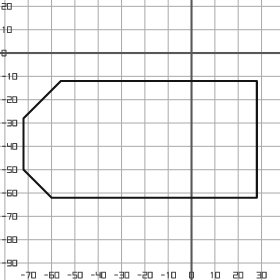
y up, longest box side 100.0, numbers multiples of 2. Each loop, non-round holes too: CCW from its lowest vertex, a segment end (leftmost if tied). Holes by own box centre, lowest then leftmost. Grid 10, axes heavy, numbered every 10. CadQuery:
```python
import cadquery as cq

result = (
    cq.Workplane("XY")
    .moveTo(-60.0, -62.0)
    .lineTo(28.0, -62.0)
    .lineTo(28.0, -12.0)
    .lineTo(-56.0, -12.0)
    .lineTo(-72.0, -28.0)
    .lineTo(-72.0, -50.0)
    .close()
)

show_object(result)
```